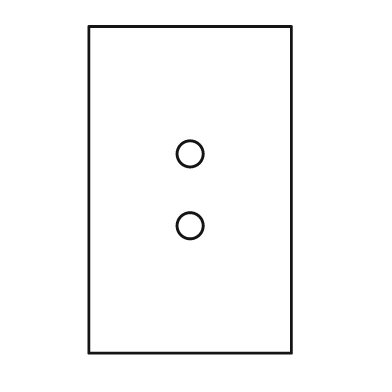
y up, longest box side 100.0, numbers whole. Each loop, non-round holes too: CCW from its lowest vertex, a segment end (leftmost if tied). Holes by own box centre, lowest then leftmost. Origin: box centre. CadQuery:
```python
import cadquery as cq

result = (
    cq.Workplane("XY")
    .moveTo(-31.0, -50.0)
    .lineTo(31.0, -50.0)
    .lineTo(31.0, 50.0)
    .lineTo(-31.0, 50.0)
    .close()
    .moveTo(0.0, -11.0)
    .circle(4.0)
    .moveTo(0.0, 11.0)
    .circle(4.0)
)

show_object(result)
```